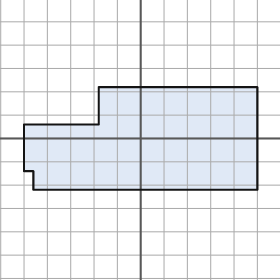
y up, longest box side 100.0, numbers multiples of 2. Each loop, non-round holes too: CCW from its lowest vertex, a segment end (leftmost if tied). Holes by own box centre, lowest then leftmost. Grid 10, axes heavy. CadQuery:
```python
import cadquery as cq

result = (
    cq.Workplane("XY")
    .moveTo(-46.0, -22.0)
    .lineTo(50.0, -22.0)
    .lineTo(50.0, 22.0)
    .lineTo(-18.0, 22.0)
    .lineTo(-18.0, 6.0)
    .lineTo(-50.0, 6.0)
    .lineTo(-50.0, -14.0)
    .lineTo(-46.0, -14.0)
    .close()
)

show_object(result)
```